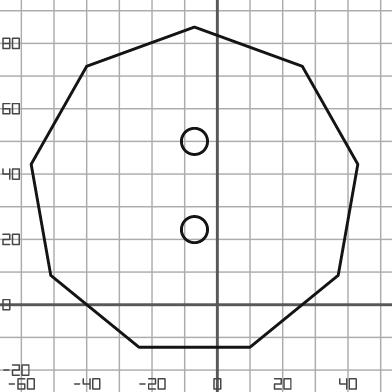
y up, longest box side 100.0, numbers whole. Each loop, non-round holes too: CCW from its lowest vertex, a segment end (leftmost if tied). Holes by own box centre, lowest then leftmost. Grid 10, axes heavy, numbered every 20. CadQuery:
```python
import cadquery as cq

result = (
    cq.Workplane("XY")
    .moveTo(-24.0, -13.0)
    .lineTo(10.0, -13.0)
    .lineTo(37.0, 9.0)
    .lineTo(43.0, 43.0)
    .lineTo(26.0, 73.0)
    .lineTo(-7.0, 85.0)
    .lineTo(-40.0, 73.0)
    .lineTo(-57.0, 43.0)
    .lineTo(-51.0, 9.0)
    .close()
    .moveTo(-7.0, 23.0)
    .circle(4.0)
    .moveTo(-7.0, 50.0)
    .circle(4.0)
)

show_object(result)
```